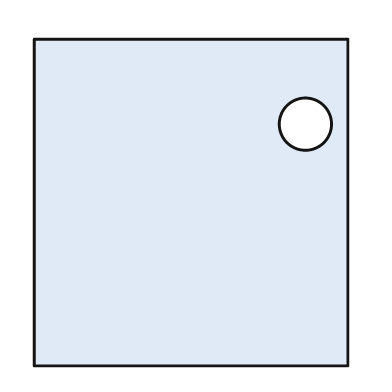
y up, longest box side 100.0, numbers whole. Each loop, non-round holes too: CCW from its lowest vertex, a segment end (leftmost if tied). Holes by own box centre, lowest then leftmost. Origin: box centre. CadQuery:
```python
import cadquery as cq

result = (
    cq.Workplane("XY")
    .moveTo(-48.0, -50.0)
    .lineTo(48.0, -50.0)
    .lineTo(48.0, 50.0)
    .lineTo(-48.0, 50.0)
    .close()
    .moveTo(35.0, 24.0)
    .circle(8.0)
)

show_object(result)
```